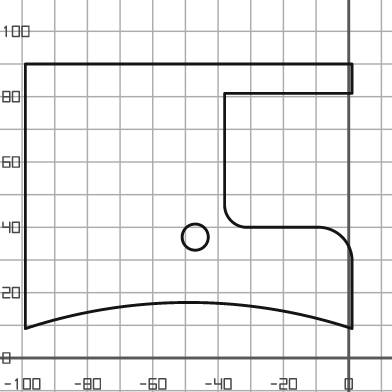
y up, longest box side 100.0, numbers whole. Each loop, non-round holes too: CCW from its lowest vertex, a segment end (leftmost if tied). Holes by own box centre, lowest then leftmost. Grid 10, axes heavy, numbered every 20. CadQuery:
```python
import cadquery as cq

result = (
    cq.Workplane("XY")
    .moveTo(-99.0, 9.0)
    .threePointArc((-49.0, 17.0), (1.0, 9.0))
    .lineTo(1.0, 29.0)
    .threePointArc((-2.0, 37.0), (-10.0, 40.0))
    .lineTo(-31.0, 40.0)
    .threePointArc((-36.0, 42.0), (-38.0, 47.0))
    .lineTo(-38.0, 81.0)
    .lineTo(1.0, 81.0)
    .lineTo(1.0, 90.0)
    .lineTo(-99.0, 90.0)
    .close()
    .moveTo(-47.0, 37.0)
    .circle(4.0)
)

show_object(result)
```